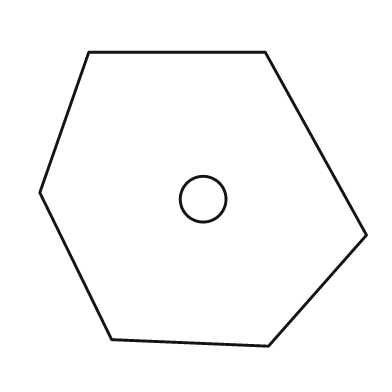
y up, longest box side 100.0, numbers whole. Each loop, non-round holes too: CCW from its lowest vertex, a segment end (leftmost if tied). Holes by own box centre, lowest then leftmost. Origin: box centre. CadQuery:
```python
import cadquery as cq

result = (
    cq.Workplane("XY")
    .moveTo(20.0, -45.0)
    .lineTo(50.0, -11.0)
    .lineTo(19.0, 45.0)
    .lineTo(-35.0, 45.0)
    .lineTo(-50.0, 2.0)
    .lineTo(-28.0, -43.0)
    .close()
    .moveTo(0.0, 0.0)
    .circle(7.0)
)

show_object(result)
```